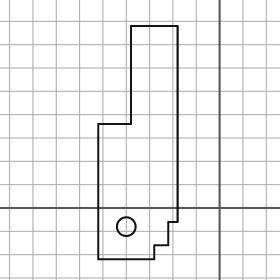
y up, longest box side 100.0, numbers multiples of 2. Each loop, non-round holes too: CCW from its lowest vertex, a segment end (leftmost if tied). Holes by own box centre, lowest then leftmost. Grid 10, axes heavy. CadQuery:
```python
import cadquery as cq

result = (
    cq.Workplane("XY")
    .moveTo(-52.0, -22.0)
    .lineTo(-28.0, -22.0)
    .lineTo(-28.0, -16.0)
    .lineTo(-22.0, -16.0)
    .lineTo(-22.0, -6.0)
    .lineTo(-18.0, -6.0)
    .lineTo(-18.0, 78.0)
    .lineTo(-38.0, 78.0)
    .lineTo(-38.0, 36.0)
    .lineTo(-52.0, 36.0)
    .close()
    .moveTo(-40.0, -8.0)
    .circle(4.0)
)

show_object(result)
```